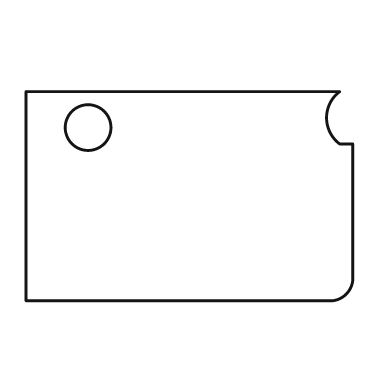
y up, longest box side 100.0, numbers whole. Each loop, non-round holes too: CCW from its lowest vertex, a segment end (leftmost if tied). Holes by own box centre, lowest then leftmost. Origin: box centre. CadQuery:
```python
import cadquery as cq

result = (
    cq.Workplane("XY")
    .moveTo(-50.0, -32.0)
    .lineTo(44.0, -32.0)
    .threePointArc((48.0, -30.0), (50.0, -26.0))
    .lineTo(50.0, 16.0)
    .lineTo(46.0, 16.0)
    .threePointArc((42.0, 24.0), (46.0, 32.0))
    .lineTo(-50.0, 32.0)
    .close()
    .moveTo(-31.0, 21.0)
    .circle(7.0)
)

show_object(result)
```